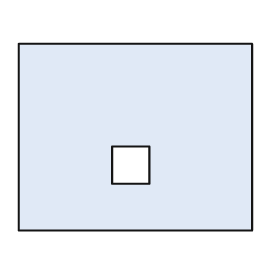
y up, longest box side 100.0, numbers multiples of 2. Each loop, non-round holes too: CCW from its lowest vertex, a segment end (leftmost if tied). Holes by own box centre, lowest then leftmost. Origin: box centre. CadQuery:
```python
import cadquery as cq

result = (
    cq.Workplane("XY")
    .moveTo(-50.0, -40.0)
    .lineTo(50.0, -40.0)
    .lineTo(50.0, 40.0)
    .lineTo(-50.0, 40.0)
    .close()
    .moveTo(-10.0, -20.0)
    .lineTo(6.0, -20.0)
    .lineTo(6.0, -4.0)
    .lineTo(-10.0, -4.0)
    .close()
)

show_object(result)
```